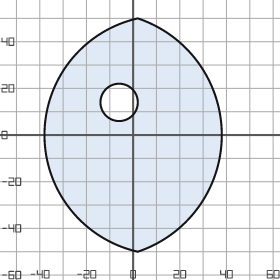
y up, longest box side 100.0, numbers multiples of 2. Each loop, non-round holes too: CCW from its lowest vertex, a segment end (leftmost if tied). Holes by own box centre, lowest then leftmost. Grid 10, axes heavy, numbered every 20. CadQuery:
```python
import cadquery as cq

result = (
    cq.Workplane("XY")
    .moveTo(2.0, -50.0)
    .threePointArc((38.0, 0.0), (2.0, 50.0))
    .threePointArc((-38.0, 0.0), (2.0, -50.0))
    .close()
    .moveTo(-6.0, 14.0)
    .circle(8.0)
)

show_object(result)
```